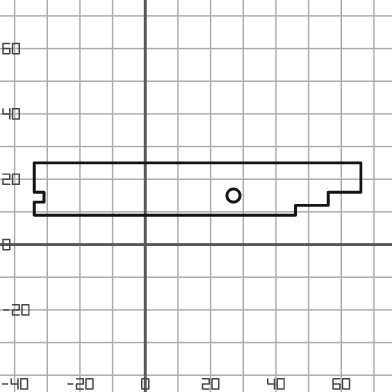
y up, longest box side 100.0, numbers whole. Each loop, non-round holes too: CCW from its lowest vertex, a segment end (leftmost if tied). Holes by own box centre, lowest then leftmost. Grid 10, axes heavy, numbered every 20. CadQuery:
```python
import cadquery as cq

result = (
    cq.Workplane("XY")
    .moveTo(-34.0, 9.0)
    .lineTo(46.0, 9.0)
    .lineTo(46.0, 12.0)
    .lineTo(56.0, 12.0)
    .lineTo(56.0, 16.0)
    .lineTo(66.0, 16.0)
    .lineTo(66.0, 25.0)
    .lineTo(-34.0, 25.0)
    .lineTo(-34.0, 16.0)
    .lineTo(-31.0, 16.0)
    .lineTo(-31.0, 13.0)
    .lineTo(-34.0, 13.0)
    .close()
    .moveTo(27.0, 15.0)
    .circle(2.0)
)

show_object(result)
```